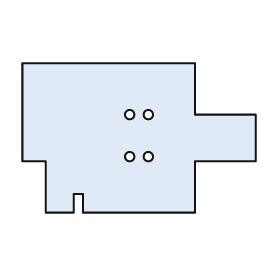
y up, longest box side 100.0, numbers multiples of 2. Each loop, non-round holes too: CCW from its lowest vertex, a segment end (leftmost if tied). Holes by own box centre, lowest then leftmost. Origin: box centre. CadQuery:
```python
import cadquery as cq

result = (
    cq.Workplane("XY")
    .moveTo(-40.0, -32.0)
    .lineTo(-28.0, -32.0)
    .lineTo(-28.0, -24.0)
    .lineTo(-24.0, -24.0)
    .lineTo(-24.0, -32.0)
    .lineTo(24.0, -32.0)
    .lineTo(24.0, -10.0)
    .lineTo(50.0, -10.0)
    .lineTo(50.0, 10.0)
    .lineTo(24.0, 10.0)
    .lineTo(24.0, 32.0)
    .lineTo(-50.0, 32.0)
    .lineTo(-50.0, -10.0)
    .lineTo(-40.0, -10.0)
    .close()
    .moveTo(-4.0, -8.0)
    .circle(2.0)
    .moveTo(4.0, -8.0)
    .circle(2.0)
    .moveTo(-4.0, 10.0)
    .circle(2.0)
    .moveTo(4.0, 10.0)
    .circle(2.0)
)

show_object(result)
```